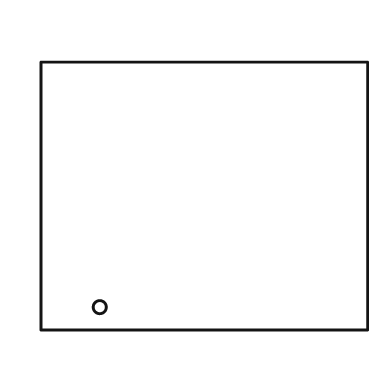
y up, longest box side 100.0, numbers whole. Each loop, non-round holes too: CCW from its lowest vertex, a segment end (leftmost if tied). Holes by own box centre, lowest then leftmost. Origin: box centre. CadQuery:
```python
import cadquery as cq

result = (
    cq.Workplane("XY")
    .moveTo(-50.0, -41.0)
    .lineTo(50.0, -41.0)
    .lineTo(50.0, 41.0)
    .lineTo(-50.0, 41.0)
    .close()
    .moveTo(-32.0, -34.0)
    .circle(2.0)
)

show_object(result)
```